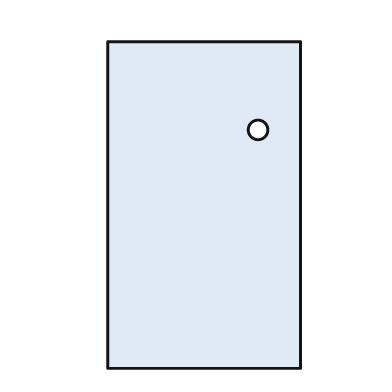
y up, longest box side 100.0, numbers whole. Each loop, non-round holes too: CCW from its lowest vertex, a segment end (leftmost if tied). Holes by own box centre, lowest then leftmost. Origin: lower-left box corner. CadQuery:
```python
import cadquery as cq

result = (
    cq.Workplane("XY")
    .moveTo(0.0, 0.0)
    .lineTo(59.0, 0.0)
    .lineTo(59.0, 100.0)
    .lineTo(0.0, 100.0)
    .close()
    .moveTo(46.0, 73.0)
    .circle(3.0)
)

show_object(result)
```